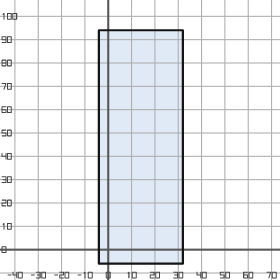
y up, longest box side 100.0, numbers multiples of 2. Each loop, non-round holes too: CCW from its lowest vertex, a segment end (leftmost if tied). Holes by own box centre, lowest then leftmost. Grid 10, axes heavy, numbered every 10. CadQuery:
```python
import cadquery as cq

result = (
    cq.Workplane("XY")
    .moveTo(-4.0, -6.0)
    .lineTo(32.0, -6.0)
    .lineTo(32.0, 94.0)
    .lineTo(-4.0, 94.0)
    .close()
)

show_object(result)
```